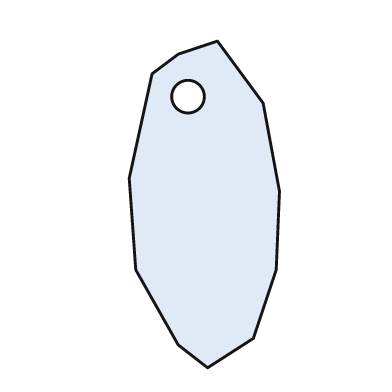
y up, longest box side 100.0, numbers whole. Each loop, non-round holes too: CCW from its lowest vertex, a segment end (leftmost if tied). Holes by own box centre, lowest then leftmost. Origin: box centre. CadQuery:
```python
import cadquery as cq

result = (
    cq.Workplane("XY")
    .moveTo(1.0, -50.0)
    .lineTo(15.0, -41.0)
    .lineTo(22.0, -20.0)
    .lineTo(23.0, 4.0)
    .lineTo(18.0, 31.0)
    .lineTo(4.0, 50.0)
    .lineTo(-8.0, 46.0)
    .lineTo(-16.0, 40.0)
    .lineTo(-23.0, 8.0)
    .lineTo(-21.0, -20.0)
    .lineTo(-8.0, -43.0)
    .close()
    .moveTo(-5.0, 33.0)
    .circle(5.0)
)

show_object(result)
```